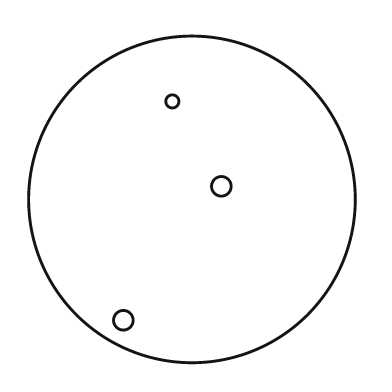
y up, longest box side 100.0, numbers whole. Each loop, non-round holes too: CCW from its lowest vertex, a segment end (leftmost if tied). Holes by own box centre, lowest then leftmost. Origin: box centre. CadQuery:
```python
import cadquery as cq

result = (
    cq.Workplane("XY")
    .moveTo(0.0, 0.0)
    .circle(50.0)
    .moveTo(-21.0, -37.0)
    .circle(3.0)
    .moveTo(9.0, 4.0)
    .circle(3.0)
    .moveTo(-6.0, 30.0)
    .circle(2.0)
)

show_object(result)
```